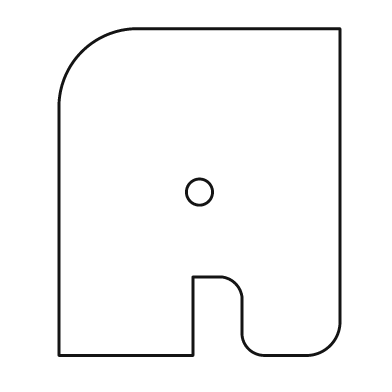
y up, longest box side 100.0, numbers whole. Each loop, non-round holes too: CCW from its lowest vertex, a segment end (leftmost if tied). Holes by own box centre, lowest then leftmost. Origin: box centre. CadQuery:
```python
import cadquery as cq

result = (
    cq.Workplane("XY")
    .moveTo(-43.0, -50.0)
    .lineTo(-2.0, -50.0)
    .lineTo(-2.0, -26.0)
    .lineTo(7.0, -26.0)
    .threePointArc((11.0, -28.0), (13.0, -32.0))
    .lineTo(13.0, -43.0)
    .threePointArc((15.0, -48.0), (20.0, -50.0))
    .lineTo(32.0, -50.0)
    .threePointArc((40.0, -47.0), (43.0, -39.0))
    .lineTo(43.0, 50.0)
    .lineTo(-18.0, 50.0)
    .threePointArc((-36.0, 43.0), (-43.0, 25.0))
    .close()
    .moveTo(0.0, 0.0)
    .circle(4.0)
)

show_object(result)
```